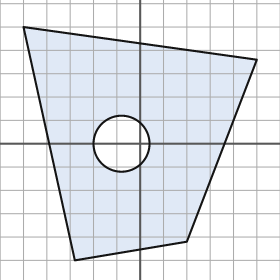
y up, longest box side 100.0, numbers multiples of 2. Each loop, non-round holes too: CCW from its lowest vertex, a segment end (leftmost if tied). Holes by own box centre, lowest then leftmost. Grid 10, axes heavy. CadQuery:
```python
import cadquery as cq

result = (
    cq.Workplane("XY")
    .moveTo(-28.0, -50.0)
    .lineTo(20.0, -42.0)
    .lineTo(50.0, 36.0)
    .lineTo(-50.0, 50.0)
    .close()
    .moveTo(-8.0, 0.0)
    .circle(12.0)
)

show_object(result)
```